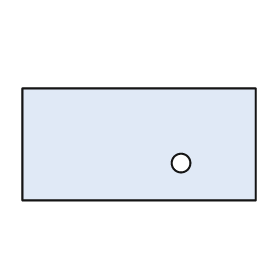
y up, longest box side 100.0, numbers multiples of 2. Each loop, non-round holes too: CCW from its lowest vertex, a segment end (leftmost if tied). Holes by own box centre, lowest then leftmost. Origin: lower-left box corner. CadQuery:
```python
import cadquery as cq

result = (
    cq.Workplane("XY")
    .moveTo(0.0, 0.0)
    .lineTo(100.0, 0.0)
    .lineTo(100.0, 48.0)
    .lineTo(0.0, 48.0)
    .close()
    .moveTo(68.0, 16.0)
    .circle(4.0)
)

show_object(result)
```